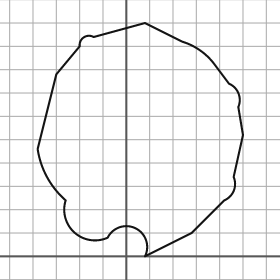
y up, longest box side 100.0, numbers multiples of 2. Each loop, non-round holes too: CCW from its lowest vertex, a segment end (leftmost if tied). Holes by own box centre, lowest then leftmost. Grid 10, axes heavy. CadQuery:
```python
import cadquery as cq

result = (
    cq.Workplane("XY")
    .moveTo(8.0, 0.0)
    .lineTo(28.0, 10.0)
    .lineTo(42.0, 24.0)
    .threePointArc((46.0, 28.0), (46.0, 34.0))
    .lineTo(50.0, 52.0)
    .lineTo(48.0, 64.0)
    .threePointArc((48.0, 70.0), (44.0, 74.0))
    .lineTo(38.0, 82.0)
    .threePointArc((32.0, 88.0), (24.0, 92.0))
    .lineTo(8.0, 100.0)
    .lineTo(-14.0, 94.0)
    .threePointArc((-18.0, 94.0), (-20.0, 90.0))
    .lineTo(-30.0, 78.0)
    .lineTo(-38.0, 46.0)
    .threePointArc((-34.0, 34.0), (-26.0, 24.0))
    .threePointArc((-22.0, 10.0), (-8.0, 8.0))
    .threePointArc((4.0, 12.0), (8.0, 0.0))
    .close()
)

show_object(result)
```